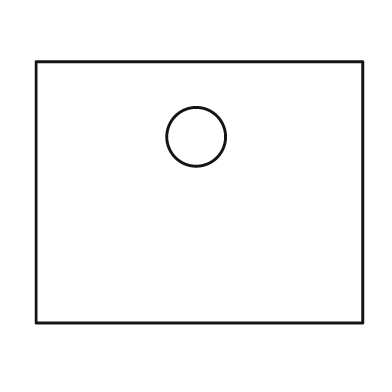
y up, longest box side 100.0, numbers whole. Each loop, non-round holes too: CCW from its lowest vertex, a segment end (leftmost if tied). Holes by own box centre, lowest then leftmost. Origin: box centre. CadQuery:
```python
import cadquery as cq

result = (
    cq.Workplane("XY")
    .moveTo(-50.0, -40.0)
    .lineTo(50.0, -40.0)
    .lineTo(50.0, 40.0)
    .lineTo(-50.0, 40.0)
    .close()
    .moveTo(-1.0, 17.0)
    .circle(9.0)
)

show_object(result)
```